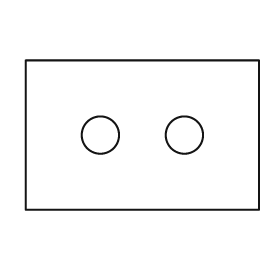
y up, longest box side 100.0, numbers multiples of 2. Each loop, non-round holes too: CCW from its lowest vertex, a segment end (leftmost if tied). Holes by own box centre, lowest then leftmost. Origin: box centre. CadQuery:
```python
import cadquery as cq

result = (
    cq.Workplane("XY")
    .moveTo(-50.0, -32.0)
    .lineTo(50.0, -32.0)
    .lineTo(50.0, 32.0)
    .lineTo(-50.0, 32.0)
    .close()
    .moveTo(-18.0, 0.0)
    .circle(8.0)
    .moveTo(18.0, 0.0)
    .circle(8.0)
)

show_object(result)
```